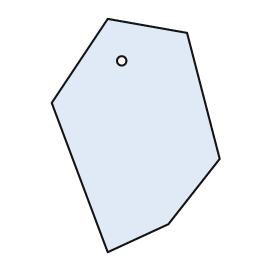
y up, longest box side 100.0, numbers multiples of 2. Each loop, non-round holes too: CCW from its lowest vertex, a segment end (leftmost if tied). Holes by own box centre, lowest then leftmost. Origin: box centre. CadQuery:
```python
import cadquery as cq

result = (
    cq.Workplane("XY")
    .moveTo(-12.0, -50.0)
    .lineTo(14.0, -38.0)
    .lineTo(36.0, -10.0)
    .lineTo(22.0, 44.0)
    .lineTo(-12.0, 50.0)
    .lineTo(-36.0, 14.0)
    .close()
    .moveTo(-6.0, 32.0)
    .circle(2.0)
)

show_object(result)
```